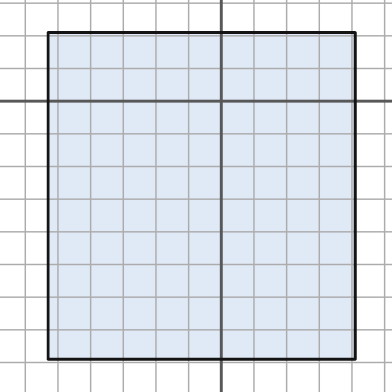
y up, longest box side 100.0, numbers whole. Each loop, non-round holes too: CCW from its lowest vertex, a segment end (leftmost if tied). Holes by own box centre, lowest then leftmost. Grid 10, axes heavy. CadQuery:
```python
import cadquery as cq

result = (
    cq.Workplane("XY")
    .moveTo(-53.0, -79.0)
    .lineTo(41.0, -79.0)
    .lineTo(41.0, 21.0)
    .lineTo(-53.0, 21.0)
    .close()
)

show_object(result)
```